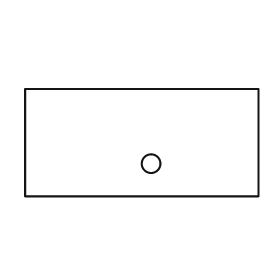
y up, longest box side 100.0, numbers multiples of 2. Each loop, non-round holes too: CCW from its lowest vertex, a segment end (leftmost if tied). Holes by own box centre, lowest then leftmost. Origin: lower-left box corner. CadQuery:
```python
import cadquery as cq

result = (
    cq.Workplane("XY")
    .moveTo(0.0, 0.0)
    .lineTo(100.0, 0.0)
    .lineTo(100.0, 46.0)
    .lineTo(0.0, 46.0)
    .close()
    .moveTo(54.0, 14.0)
    .circle(4.0)
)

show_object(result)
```